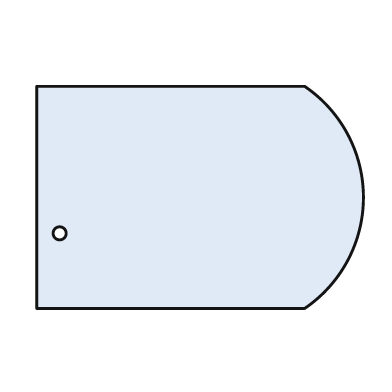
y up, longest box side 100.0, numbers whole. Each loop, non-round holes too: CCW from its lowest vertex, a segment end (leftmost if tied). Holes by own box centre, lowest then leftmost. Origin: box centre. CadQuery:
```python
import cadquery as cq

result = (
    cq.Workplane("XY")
    .moveTo(-50.0, -34.0)
    .lineTo(32.0, -34.0)
    .threePointArc((50.0, 0.0), (32.0, 34.0))
    .lineTo(-50.0, 34.0)
    .close()
    .moveTo(-43.0, -11.0)
    .circle(2.0)
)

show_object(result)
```